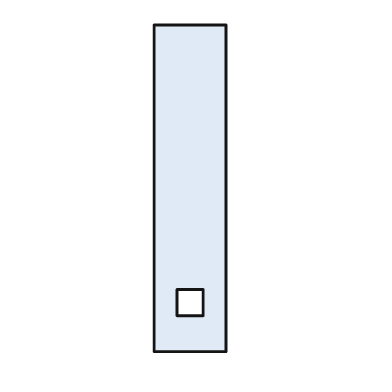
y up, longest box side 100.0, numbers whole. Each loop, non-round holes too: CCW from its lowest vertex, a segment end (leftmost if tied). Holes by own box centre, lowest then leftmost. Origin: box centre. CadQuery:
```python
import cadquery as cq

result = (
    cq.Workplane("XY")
    .moveTo(-11.0, -50.0)
    .lineTo(11.0, -50.0)
    .lineTo(11.0, 50.0)
    .lineTo(-11.0, 50.0)
    .close()
    .moveTo(-4.0, -39.0)
    .lineTo(4.0, -39.0)
    .lineTo(4.0, -31.0)
    .lineTo(-4.0, -31.0)
    .close()
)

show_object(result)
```